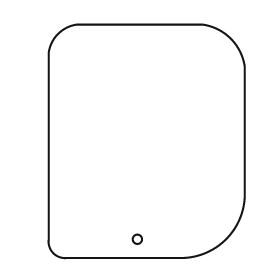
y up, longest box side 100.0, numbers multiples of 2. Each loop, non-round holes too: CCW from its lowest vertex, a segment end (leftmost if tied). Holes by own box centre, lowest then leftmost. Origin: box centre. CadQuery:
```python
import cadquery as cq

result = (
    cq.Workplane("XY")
    .moveTo(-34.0, -50.0)
    .lineTo(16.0, -50.0)
    .threePointArc((34.0, -42.0), (42.0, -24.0))
    .lineTo(42.0, 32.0)
    .threePointArc((36.0, 44.0), (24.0, 50.0))
    .lineTo(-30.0, 50.0)
    .threePointArc((-38.0, 46.0), (-42.0, 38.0))
    .lineTo(-42.0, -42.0)
    .threePointArc((-40.0, -48.0), (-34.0, -50.0))
    .close()
    .moveTo(-4.0, -42.0)
    .circle(2.0)
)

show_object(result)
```